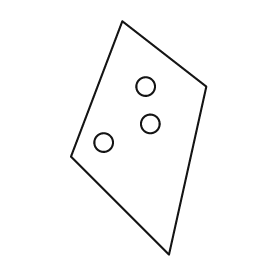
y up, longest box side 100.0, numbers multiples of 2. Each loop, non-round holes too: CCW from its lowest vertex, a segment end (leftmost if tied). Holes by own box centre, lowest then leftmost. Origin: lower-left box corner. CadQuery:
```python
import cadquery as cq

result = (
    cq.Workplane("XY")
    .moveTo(42.0, 0.0)
    .lineTo(58.0, 72.0)
    .lineTo(22.0, 100.0)
    .lineTo(0.0, 42.0)
    .close()
    .moveTo(14.0, 48.0)
    .circle(4.0)
    .moveTo(34.0, 56.0)
    .circle(4.0)
    .moveTo(32.0, 72.0)
    .circle(4.0)
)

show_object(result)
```